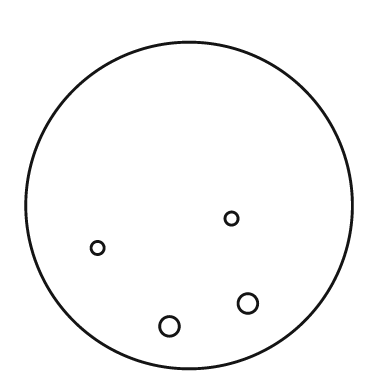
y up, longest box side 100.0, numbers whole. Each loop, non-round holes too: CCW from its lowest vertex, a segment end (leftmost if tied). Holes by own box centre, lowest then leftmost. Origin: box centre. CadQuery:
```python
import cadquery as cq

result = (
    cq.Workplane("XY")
    .moveTo(0.0, 0.0)
    .circle(50.0)
    .moveTo(-6.0, -37.0)
    .circle(3.0)
    .moveTo(18.0, -30.0)
    .circle(3.0)
    .moveTo(-28.0, -13.0)
    .circle(2.0)
    .moveTo(13.0, -4.0)
    .circle(2.0)
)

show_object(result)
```